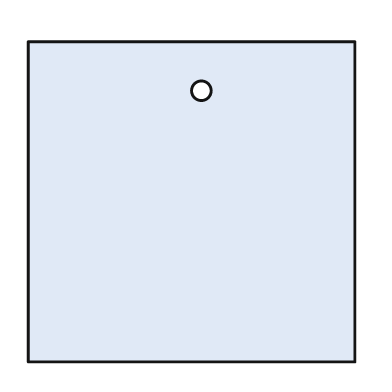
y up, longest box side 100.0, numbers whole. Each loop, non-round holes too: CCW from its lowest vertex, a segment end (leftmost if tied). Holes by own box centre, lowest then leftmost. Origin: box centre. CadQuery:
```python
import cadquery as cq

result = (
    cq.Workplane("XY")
    .moveTo(-50.0, -49.0)
    .lineTo(50.0, -49.0)
    .lineTo(50.0, 49.0)
    .lineTo(-50.0, 49.0)
    .close()
    .moveTo(3.0, 34.0)
    .circle(3.0)
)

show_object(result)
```